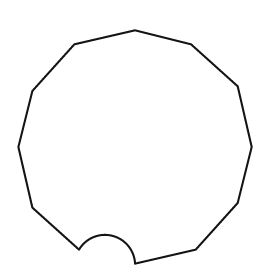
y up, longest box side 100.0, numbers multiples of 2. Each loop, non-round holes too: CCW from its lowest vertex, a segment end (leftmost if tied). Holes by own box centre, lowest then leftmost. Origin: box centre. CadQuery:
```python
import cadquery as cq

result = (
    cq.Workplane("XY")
    .moveTo(0.0, -50.0)
    .lineTo(26.0, -44.0)
    .lineTo(44.0, -24.0)
    .lineTo(50.0, 0.0)
    .lineTo(44.0, 26.0)
    .lineTo(24.0, 44.0)
    .lineTo(0.0, 50.0)
    .lineTo(-26.0, 44.0)
    .lineTo(-44.0, 24.0)
    .lineTo(-50.0, 0.0)
    .lineTo(-44.0, -26.0)
    .lineTo(-24.0, -44.0)
    .threePointArc((-10.0, -38.0), (0.0, -50.0))
    .close()
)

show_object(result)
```